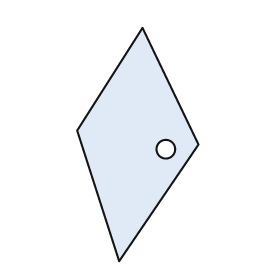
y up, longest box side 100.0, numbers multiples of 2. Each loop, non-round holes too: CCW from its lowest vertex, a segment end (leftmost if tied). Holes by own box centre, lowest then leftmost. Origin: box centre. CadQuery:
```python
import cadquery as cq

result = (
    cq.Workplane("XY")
    .moveTo(-8.0, -50.0)
    .lineTo(26.0, 0.0)
    .lineTo(2.0, 50.0)
    .lineTo(-26.0, 6.0)
    .close()
    .moveTo(12.0, -2.0)
    .circle(4.0)
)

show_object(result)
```